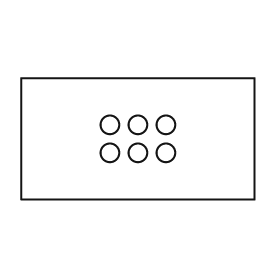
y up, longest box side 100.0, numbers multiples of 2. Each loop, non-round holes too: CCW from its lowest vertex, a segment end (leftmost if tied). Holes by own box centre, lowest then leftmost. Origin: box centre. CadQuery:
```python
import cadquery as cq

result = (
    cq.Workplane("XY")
    .moveTo(-50.0, -26.0)
    .lineTo(50.0, -26.0)
    .lineTo(50.0, 26.0)
    .lineTo(-50.0, 26.0)
    .close()
    .moveTo(-12.0, -6.0)
    .circle(4.0)
    .moveTo(0.0, -6.0)
    .circle(4.0)
    .moveTo(12.0, -6.0)
    .circle(4.0)
    .moveTo(-12.0, 6.0)
    .circle(4.0)
    .moveTo(0.0, 6.0)
    .circle(4.0)
    .moveTo(12.0, 6.0)
    .circle(4.0)
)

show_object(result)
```